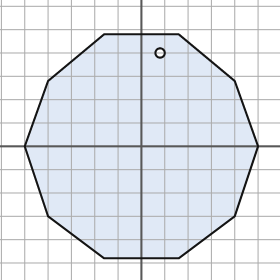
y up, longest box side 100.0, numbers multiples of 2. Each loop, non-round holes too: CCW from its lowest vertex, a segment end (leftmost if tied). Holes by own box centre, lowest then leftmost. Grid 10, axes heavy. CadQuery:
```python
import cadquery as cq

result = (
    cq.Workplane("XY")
    .moveTo(-16.0, -48.0)
    .lineTo(16.0, -48.0)
    .lineTo(40.0, -30.0)
    .lineTo(50.0, 0.0)
    .lineTo(40.0, 28.0)
    .lineTo(16.0, 48.0)
    .lineTo(-16.0, 48.0)
    .lineTo(-40.0, 28.0)
    .lineTo(-50.0, 0.0)
    .lineTo(-40.0, -30.0)
    .close()
    .moveTo(8.0, 40.0)
    .circle(2.0)
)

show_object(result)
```